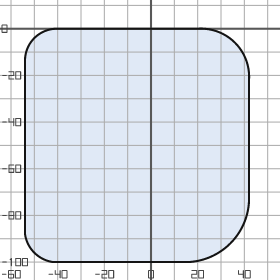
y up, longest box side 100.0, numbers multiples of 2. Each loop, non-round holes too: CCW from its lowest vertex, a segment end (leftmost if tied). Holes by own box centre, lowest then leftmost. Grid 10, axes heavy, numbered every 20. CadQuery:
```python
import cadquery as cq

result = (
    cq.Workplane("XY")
    .moveTo(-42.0, -100.0)
    .lineTo(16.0, -100.0)
    .threePointArc((34.0, -92.0), (42.0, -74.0))
    .lineTo(42.0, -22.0)
    .threePointArc((36.0, -6.0), (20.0, 0.0))
    .lineTo(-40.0, 0.0)
    .threePointArc((-50.0, -4.0), (-54.0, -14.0))
    .lineTo(-54.0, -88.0)
    .threePointArc((-50.0, -96.0), (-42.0, -100.0))
    .close()
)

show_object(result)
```